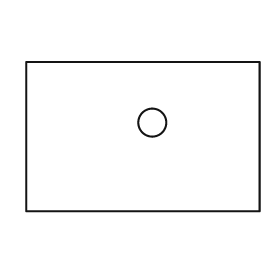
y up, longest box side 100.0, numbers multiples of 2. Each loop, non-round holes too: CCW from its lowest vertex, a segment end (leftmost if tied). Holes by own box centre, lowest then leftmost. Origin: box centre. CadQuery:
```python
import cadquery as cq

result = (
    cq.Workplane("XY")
    .moveTo(-50.0, -32.0)
    .lineTo(50.0, -32.0)
    .lineTo(50.0, 32.0)
    .lineTo(-50.0, 32.0)
    .close()
    .moveTo(4.0, 6.0)
    .circle(6.0)
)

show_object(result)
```